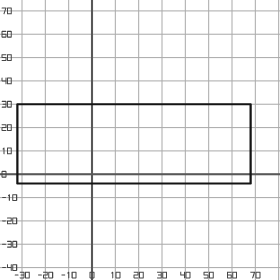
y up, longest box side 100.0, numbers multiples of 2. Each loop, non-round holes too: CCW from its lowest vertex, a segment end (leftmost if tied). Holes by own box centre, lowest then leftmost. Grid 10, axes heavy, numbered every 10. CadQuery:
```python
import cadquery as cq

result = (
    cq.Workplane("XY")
    .moveTo(-32.0, -4.0)
    .lineTo(68.0, -4.0)
    .lineTo(68.0, 30.0)
    .lineTo(-32.0, 30.0)
    .close()
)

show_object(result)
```